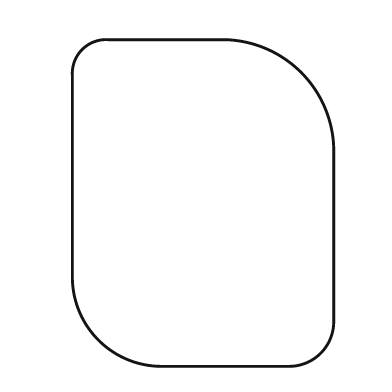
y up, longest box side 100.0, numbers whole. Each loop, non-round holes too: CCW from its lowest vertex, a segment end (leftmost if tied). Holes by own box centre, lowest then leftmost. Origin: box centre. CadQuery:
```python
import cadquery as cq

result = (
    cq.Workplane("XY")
    .moveTo(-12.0, -50.0)
    .lineTo(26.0, -50.0)
    .threePointArc((36.0, -46.0), (40.0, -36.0))
    .lineTo(40.0, 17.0)
    .threePointArc((30.0, 40.0), (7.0, 50.0))
    .lineTo(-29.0, 50.0)
    .threePointArc((-37.0, 47.0), (-40.0, 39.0))
    .lineTo(-40.0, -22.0)
    .threePointArc((-32.0, -42.0), (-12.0, -50.0))
    .close()
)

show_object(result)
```